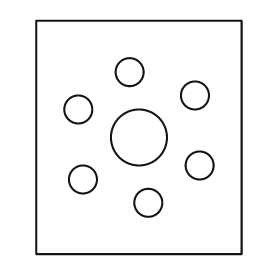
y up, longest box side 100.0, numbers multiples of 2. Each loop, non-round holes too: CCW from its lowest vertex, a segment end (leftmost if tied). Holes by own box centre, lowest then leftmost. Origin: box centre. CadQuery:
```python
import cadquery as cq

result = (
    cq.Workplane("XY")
    .moveTo(-44.0, -50.0)
    .lineTo(44.0, -50.0)
    .lineTo(44.0, 50.0)
    .lineTo(-44.0, 50.0)
    .close()
    .moveTo(4.0, -28.0)
    .circle(6.0)
    .moveTo(-24.0, -18.0)
    .circle(6.0)
    .moveTo(26.0, -12.0)
    .circle(6.0)
    .moveTo(0.0, 0.0)
    .circle(12.0)
    .moveTo(-26.0, 12.0)
    .circle(6.0)
    .moveTo(24.0, 18.0)
    .circle(6.0)
    .moveTo(-4.0, 28.0)
    .circle(6.0)
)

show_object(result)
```